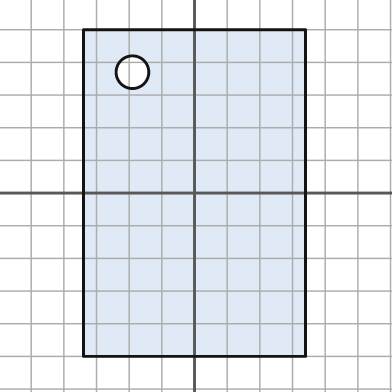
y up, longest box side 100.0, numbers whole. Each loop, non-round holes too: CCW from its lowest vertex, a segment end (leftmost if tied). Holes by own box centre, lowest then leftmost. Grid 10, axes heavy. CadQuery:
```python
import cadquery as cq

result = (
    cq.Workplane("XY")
    .moveTo(-34.0, -50.0)
    .lineTo(34.0, -50.0)
    .lineTo(34.0, 50.0)
    .lineTo(-34.0, 50.0)
    .close()
    .moveTo(-19.0, 37.0)
    .circle(5.0)
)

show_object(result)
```